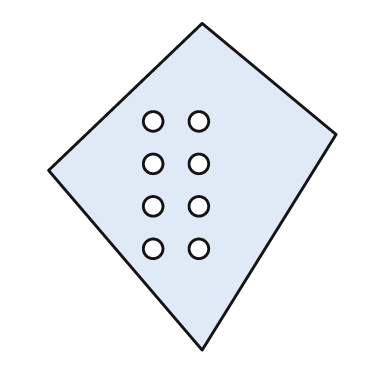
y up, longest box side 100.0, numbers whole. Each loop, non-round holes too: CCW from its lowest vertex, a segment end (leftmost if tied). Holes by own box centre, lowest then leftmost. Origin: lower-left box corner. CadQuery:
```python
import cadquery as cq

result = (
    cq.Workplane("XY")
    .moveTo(47.0, 0.0)
    .lineTo(88.0, 66.0)
    .lineTo(47.0, 100.0)
    .lineTo(0.0, 55.0)
    .close()
    .moveTo(32.0, 31.0)
    .circle(3.0)
    .moveTo(46.0, 31.0)
    .circle(3.0)
    .moveTo(32.0, 44.0)
    .circle(3.0)
    .moveTo(46.0, 44.0)
    .circle(3.0)
    .moveTo(32.0, 57.0)
    .circle(3.0)
    .moveTo(46.0, 57.0)
    .circle(3.0)
    .moveTo(32.0, 70.0)
    .circle(3.0)
    .moveTo(46.0, 70.0)
    .circle(3.0)
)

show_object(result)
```